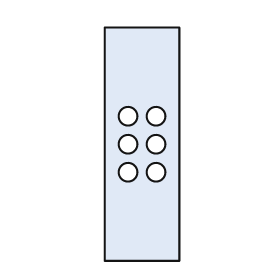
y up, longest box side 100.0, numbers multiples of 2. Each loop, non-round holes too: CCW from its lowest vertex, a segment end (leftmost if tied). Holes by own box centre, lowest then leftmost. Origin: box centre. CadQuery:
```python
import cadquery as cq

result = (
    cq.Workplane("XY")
    .moveTo(-16.0, -50.0)
    .lineTo(16.0, -50.0)
    .lineTo(16.0, 50.0)
    .lineTo(-16.0, 50.0)
    .close()
    .moveTo(-6.0, -12.0)
    .circle(4.0)
    .moveTo(6.0, -12.0)
    .circle(4.0)
    .moveTo(-6.0, 0.0)
    .circle(4.0)
    .moveTo(6.0, 0.0)
    .circle(4.0)
    .moveTo(-6.0, 12.0)
    .circle(4.0)
    .moveTo(6.0, 12.0)
    .circle(4.0)
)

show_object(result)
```